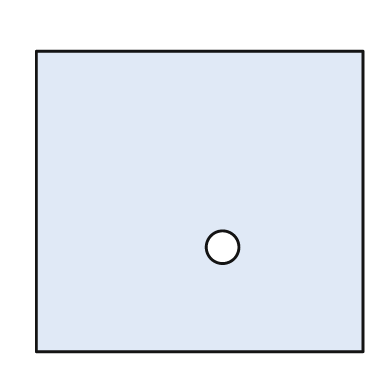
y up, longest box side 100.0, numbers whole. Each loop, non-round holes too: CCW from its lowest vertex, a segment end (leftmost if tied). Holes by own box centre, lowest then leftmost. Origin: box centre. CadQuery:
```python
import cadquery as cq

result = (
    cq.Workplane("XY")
    .moveTo(-50.0, -46.0)
    .lineTo(50.0, -46.0)
    .lineTo(50.0, 46.0)
    .lineTo(-50.0, 46.0)
    .close()
    .moveTo(7.0, -14.0)
    .circle(5.0)
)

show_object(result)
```